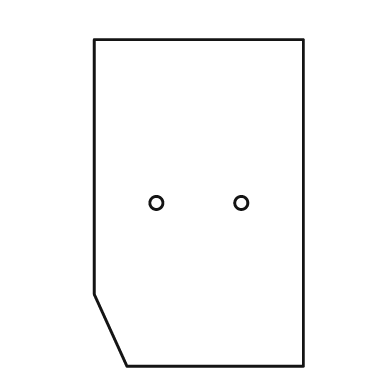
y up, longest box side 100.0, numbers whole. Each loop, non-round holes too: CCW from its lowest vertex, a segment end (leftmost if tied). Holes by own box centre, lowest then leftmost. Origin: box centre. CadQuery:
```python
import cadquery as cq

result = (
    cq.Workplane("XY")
    .moveTo(-22.0, -50.0)
    .lineTo(32.0, -50.0)
    .lineTo(32.0, 50.0)
    .lineTo(-32.0, 50.0)
    .lineTo(-32.0, -28.0)
    .close()
    .moveTo(-13.0, 0.0)
    .circle(2.0)
    .moveTo(13.0, 0.0)
    .circle(2.0)
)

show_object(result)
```